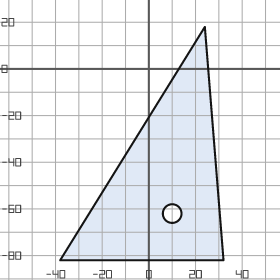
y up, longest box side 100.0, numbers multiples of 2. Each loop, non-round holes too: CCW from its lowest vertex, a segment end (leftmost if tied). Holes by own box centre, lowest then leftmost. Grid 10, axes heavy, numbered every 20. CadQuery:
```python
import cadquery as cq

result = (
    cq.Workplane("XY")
    .moveTo(-38.0, -82.0)
    .lineTo(32.0, -82.0)
    .lineTo(24.0, 18.0)
    .close()
    .moveTo(10.0, -62.0)
    .circle(4.0)
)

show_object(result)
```